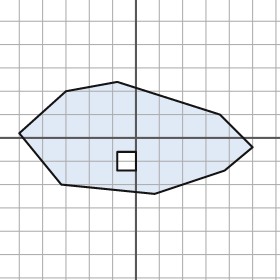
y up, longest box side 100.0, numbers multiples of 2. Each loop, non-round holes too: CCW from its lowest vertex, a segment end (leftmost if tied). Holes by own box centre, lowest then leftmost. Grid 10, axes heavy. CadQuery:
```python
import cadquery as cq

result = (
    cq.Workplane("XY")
    .moveTo(8.0, -24.0)
    .lineTo(38.0, -14.0)
    .lineTo(50.0, -4.0)
    .lineTo(36.0, 10.0)
    .lineTo(-8.0, 24.0)
    .lineTo(-30.0, 20.0)
    .lineTo(-50.0, 2.0)
    .lineTo(-32.0, -20.0)
    .close()
    .moveTo(-8.0, -14.0)
    .lineTo(0.0, -14.0)
    .lineTo(0.0, -6.0)
    .lineTo(-8.0, -6.0)
    .close()
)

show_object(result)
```